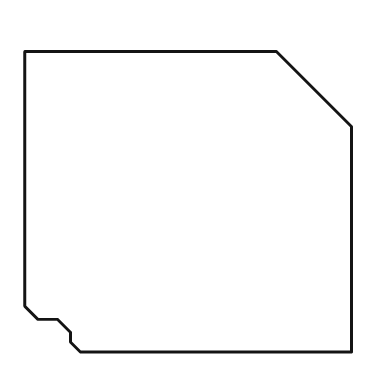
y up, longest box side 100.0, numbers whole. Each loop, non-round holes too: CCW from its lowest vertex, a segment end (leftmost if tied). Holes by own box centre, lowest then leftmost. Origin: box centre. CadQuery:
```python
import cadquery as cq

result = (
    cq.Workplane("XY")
    .moveTo(-33.0, -46.0)
    .lineTo(50.0, -46.0)
    .lineTo(50.0, 23.0)
    .lineTo(27.0, 46.0)
    .lineTo(-50.0, 46.0)
    .lineTo(-50.0, -32.0)
    .lineTo(-46.0, -36.0)
    .lineTo(-40.0, -36.0)
    .lineTo(-36.0, -40.0)
    .lineTo(-36.0, -43.0)
    .close()
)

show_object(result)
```